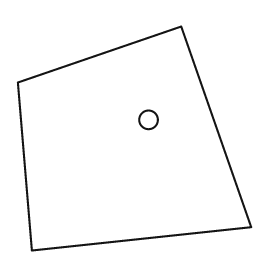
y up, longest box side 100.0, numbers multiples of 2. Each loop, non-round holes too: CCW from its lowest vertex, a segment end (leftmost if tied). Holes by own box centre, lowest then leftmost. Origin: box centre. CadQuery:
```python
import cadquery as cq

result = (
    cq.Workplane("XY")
    .moveTo(-44.0, -48.0)
    .lineTo(50.0, -38.0)
    .lineTo(20.0, 48.0)
    .lineTo(-50.0, 24.0)
    .close()
    .moveTo(6.0, 8.0)
    .circle(4.0)
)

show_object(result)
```